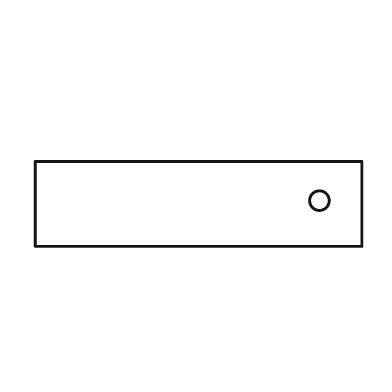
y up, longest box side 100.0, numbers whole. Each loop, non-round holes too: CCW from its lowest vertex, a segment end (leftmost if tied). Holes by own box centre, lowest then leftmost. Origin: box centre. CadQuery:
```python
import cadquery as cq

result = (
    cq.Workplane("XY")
    .moveTo(-50.0, -13.0)
    .lineTo(50.0, -13.0)
    .lineTo(50.0, 13.0)
    .lineTo(-50.0, 13.0)
    .close()
    .moveTo(37.0, 1.0)
    .circle(3.0)
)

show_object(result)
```